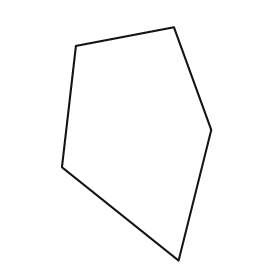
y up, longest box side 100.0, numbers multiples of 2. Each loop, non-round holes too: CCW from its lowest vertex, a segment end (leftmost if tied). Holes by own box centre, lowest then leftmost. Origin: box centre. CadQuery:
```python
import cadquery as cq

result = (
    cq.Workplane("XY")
    .moveTo(18.0, -50.0)
    .lineTo(32.0, 6.0)
    .lineTo(16.0, 50.0)
    .lineTo(-26.0, 42.0)
    .lineTo(-32.0, -10.0)
    .close()
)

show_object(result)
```